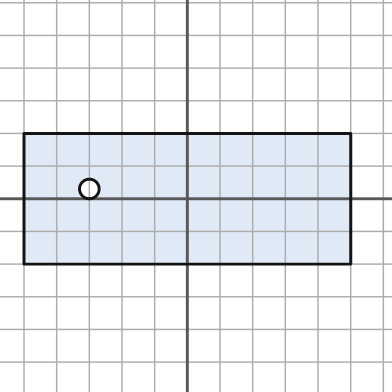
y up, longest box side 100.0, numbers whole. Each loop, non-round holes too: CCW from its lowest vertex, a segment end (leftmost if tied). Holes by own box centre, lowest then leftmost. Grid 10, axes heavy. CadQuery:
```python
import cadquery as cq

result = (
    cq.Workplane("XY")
    .moveTo(-50.0, -20.0)
    .lineTo(50.0, -20.0)
    .lineTo(50.0, 20.0)
    .lineTo(-50.0, 20.0)
    .close()
    .moveTo(-30.0, 3.0)
    .circle(3.0)
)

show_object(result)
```